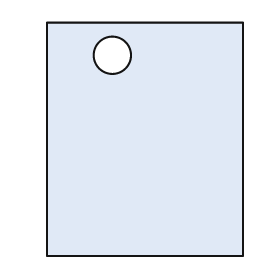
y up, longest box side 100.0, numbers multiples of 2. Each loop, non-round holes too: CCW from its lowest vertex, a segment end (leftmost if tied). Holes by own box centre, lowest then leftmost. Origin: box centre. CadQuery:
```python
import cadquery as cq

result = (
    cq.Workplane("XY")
    .moveTo(-42.0, -50.0)
    .lineTo(42.0, -50.0)
    .lineTo(42.0, 50.0)
    .lineTo(-42.0, 50.0)
    .close()
    .moveTo(-14.0, 36.0)
    .circle(8.0)
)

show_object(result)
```